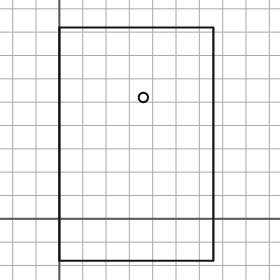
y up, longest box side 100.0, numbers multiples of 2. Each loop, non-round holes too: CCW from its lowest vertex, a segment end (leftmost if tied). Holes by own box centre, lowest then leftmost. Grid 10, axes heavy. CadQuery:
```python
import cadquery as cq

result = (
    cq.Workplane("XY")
    .moveTo(0.0, -18.0)
    .lineTo(66.0, -18.0)
    .lineTo(66.0, 82.0)
    .lineTo(0.0, 82.0)
    .close()
    .moveTo(36.0, 52.0)
    .circle(2.0)
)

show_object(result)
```